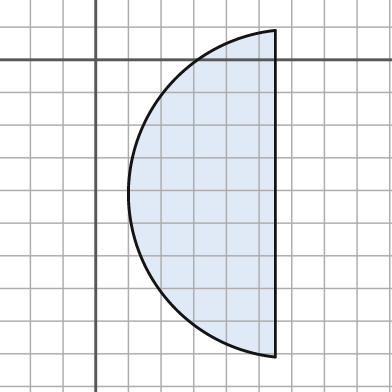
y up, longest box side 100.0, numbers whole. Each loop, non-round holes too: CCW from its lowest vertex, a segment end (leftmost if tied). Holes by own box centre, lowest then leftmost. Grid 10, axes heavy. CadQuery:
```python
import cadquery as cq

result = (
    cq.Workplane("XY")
    .moveTo(55.0, -91.0)
    .lineTo(55.0, 9.0)
    .threePointArc((10.0, -41.0), (55.0, -91.0))
    .close()
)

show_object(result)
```